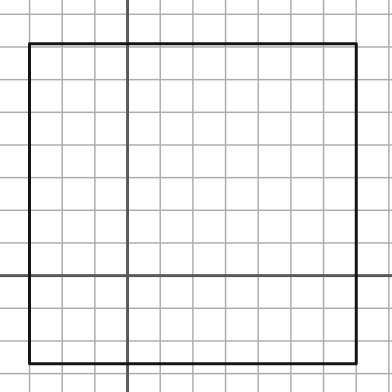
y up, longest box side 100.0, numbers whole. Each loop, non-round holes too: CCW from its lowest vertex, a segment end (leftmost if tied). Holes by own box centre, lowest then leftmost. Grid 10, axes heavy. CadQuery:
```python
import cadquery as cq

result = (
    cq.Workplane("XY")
    .moveTo(-30.0, -27.0)
    .lineTo(70.0, -27.0)
    .lineTo(70.0, 71.0)
    .lineTo(-30.0, 71.0)
    .close()
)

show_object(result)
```